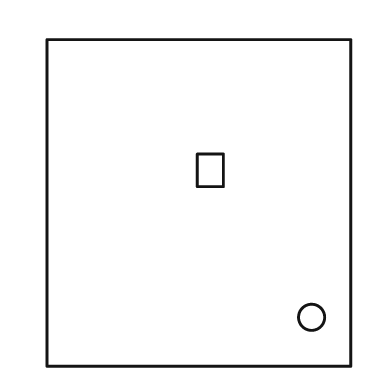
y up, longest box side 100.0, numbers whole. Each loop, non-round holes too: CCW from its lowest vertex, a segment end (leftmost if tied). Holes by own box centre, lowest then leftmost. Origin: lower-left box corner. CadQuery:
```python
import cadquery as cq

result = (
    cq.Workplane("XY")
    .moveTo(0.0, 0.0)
    .lineTo(93.0, 0.0)
    .lineTo(93.0, 100.0)
    .lineTo(0.0, 100.0)
    .close()
    .moveTo(81.0, 15.0)
    .circle(4.0)
    .moveTo(46.0, 55.0)
    .lineTo(54.0, 55.0)
    .lineTo(54.0, 65.0)
    .lineTo(46.0, 65.0)
    .close()
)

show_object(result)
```